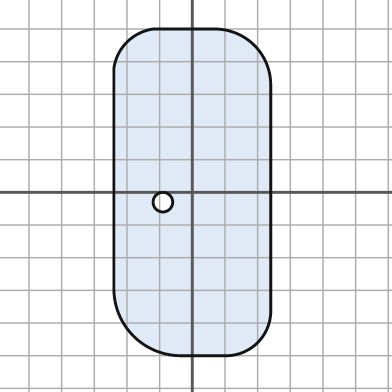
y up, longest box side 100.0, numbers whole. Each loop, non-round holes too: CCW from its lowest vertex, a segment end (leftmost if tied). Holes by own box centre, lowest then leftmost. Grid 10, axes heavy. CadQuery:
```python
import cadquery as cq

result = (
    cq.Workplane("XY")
    .moveTo(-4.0, -50.0)
    .lineTo(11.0, -50.0)
    .threePointArc((20.0, -46.0), (24.0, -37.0))
    .lineTo(24.0, 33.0)
    .threePointArc((19.0, 45.0), (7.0, 50.0))
    .lineTo(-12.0, 50.0)
    .threePointArc((-20.0, 46.0), (-24.0, 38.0))
    .lineTo(-24.0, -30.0)
    .threePointArc((-18.0, -44.0), (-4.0, -50.0))
    .close()
    .moveTo(-9.0, -3.0)
    .circle(3.0)
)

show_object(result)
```